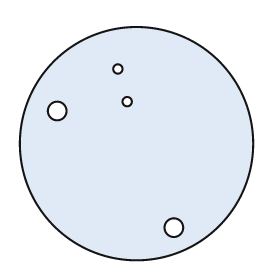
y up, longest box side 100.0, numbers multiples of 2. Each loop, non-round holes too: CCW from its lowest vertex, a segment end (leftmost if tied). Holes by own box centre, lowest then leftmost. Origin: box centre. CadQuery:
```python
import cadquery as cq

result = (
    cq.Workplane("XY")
    .moveTo(0.0, 0.0)
    .circle(50.0)
    .moveTo(16.0, -36.0)
    .circle(4.0)
    .moveTo(-34.0, 14.0)
    .circle(4.0)
    .moveTo(-4.0, 18.0)
    .circle(2.0)
    .moveTo(-8.0, 32.0)
    .circle(2.0)
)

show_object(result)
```